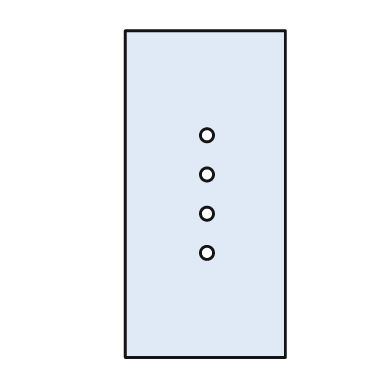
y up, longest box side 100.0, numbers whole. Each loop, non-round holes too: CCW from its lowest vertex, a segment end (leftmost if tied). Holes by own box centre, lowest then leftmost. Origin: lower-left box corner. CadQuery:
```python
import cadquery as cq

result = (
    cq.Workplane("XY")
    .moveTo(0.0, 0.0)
    .lineTo(49.0, 0.0)
    .lineTo(49.0, 100.0)
    .lineTo(0.0, 100.0)
    .close()
    .moveTo(25.0, 32.0)
    .circle(2.0)
    .moveTo(25.0, 44.0)
    .circle(2.0)
    .moveTo(25.0, 56.0)
    .circle(2.0)
    .moveTo(25.0, 68.0)
    .circle(2.0)
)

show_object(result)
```